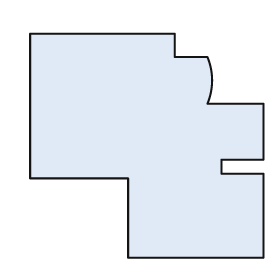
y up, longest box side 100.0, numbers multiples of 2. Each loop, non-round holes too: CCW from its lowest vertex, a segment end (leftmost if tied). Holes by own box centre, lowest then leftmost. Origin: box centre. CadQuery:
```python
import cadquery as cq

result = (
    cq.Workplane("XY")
    .moveTo(-8.0, -48.0)
    .lineTo(50.0, -48.0)
    .lineTo(50.0, -12.0)
    .lineTo(32.0, -12.0)
    .lineTo(32.0, -6.0)
    .lineTo(50.0, -6.0)
    .lineTo(50.0, 18.0)
    .lineTo(26.0, 18.0)
    .threePointArc((28.0, 28.0), (26.0, 38.0))
    .lineTo(12.0, 38.0)
    .lineTo(12.0, 48.0)
    .lineTo(-50.0, 48.0)
    .lineTo(-50.0, -14.0)
    .lineTo(-8.0, -14.0)
    .close()
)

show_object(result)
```